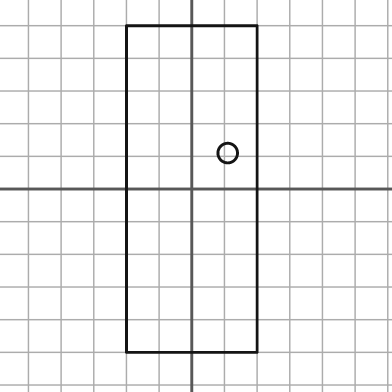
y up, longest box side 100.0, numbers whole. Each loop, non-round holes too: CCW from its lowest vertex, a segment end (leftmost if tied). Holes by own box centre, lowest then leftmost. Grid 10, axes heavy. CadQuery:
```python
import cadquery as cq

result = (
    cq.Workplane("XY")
    .moveTo(-20.0, -50.0)
    .lineTo(20.0, -50.0)
    .lineTo(20.0, 50.0)
    .lineTo(-20.0, 50.0)
    .close()
    .moveTo(11.0, 11.0)
    .circle(3.0)
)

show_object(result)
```